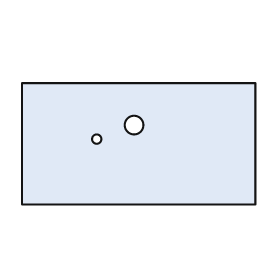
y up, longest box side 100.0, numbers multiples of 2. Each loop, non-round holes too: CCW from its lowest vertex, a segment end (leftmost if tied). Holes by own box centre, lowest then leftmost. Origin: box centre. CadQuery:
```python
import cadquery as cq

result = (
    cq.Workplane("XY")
    .moveTo(-50.0, -26.0)
    .lineTo(50.0, -26.0)
    .lineTo(50.0, 26.0)
    .lineTo(-50.0, 26.0)
    .close()
    .moveTo(-18.0, 2.0)
    .circle(2.0)
    .moveTo(-2.0, 8.0)
    .circle(4.0)
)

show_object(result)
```